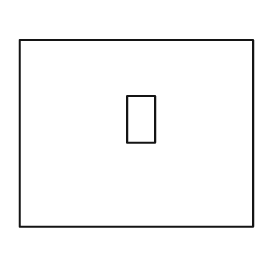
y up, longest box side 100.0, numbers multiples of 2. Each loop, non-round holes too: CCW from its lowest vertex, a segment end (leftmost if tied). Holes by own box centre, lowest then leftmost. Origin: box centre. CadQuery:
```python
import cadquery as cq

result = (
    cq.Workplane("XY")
    .moveTo(-50.0, -40.0)
    .lineTo(50.0, -40.0)
    .lineTo(50.0, 40.0)
    .lineTo(-50.0, 40.0)
    .close()
    .moveTo(-4.0, -4.0)
    .lineTo(8.0, -4.0)
    .lineTo(8.0, 16.0)
    .lineTo(-4.0, 16.0)
    .close()
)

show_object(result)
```